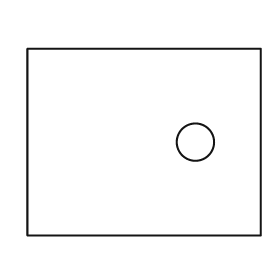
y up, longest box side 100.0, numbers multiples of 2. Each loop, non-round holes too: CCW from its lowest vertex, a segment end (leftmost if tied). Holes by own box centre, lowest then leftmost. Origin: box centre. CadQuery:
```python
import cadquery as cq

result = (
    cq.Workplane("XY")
    .moveTo(-50.0, -40.0)
    .lineTo(50.0, -40.0)
    .lineTo(50.0, 40.0)
    .lineTo(-50.0, 40.0)
    .close()
    .moveTo(22.0, 0.0)
    .circle(8.0)
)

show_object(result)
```